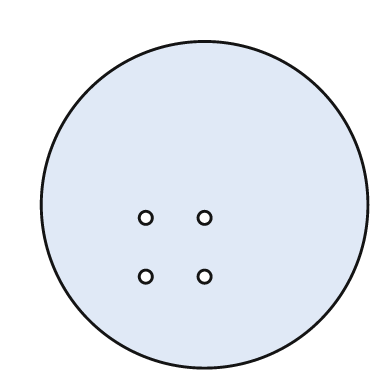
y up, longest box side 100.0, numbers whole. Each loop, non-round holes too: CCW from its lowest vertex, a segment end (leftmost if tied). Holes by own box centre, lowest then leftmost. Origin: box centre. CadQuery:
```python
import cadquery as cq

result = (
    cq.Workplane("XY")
    .moveTo(0.0, 0.0)
    .circle(50.0)
    .moveTo(-18.0, -22.0)
    .circle(2.0)
    .moveTo(0.0, -22.0)
    .circle(2.0)
    .moveTo(-18.0, -4.0)
    .circle(2.0)
    .moveTo(0.0, -4.0)
    .circle(2.0)
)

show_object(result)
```